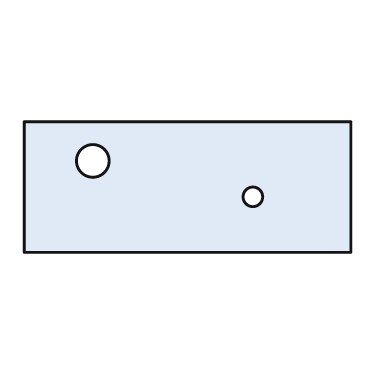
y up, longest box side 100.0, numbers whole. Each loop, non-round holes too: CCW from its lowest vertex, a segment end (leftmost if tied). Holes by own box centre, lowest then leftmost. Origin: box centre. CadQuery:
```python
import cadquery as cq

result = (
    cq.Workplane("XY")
    .moveTo(-50.0, -20.0)
    .lineTo(50.0, -20.0)
    .lineTo(50.0, 20.0)
    .lineTo(-50.0, 20.0)
    .close()
    .moveTo(20.0, -3.0)
    .circle(3.0)
    .moveTo(-29.0, 8.0)
    .circle(5.0)
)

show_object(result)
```